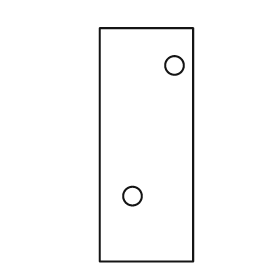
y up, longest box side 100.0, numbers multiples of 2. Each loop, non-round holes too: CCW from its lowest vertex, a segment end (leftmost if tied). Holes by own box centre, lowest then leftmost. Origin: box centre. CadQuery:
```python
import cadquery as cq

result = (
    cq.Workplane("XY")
    .moveTo(-20.0, -50.0)
    .lineTo(20.0, -50.0)
    .lineTo(20.0, 50.0)
    .lineTo(-20.0, 50.0)
    .close()
    .moveTo(-6.0, -22.0)
    .circle(4.0)
    .moveTo(12.0, 34.0)
    .circle(4.0)
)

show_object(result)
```